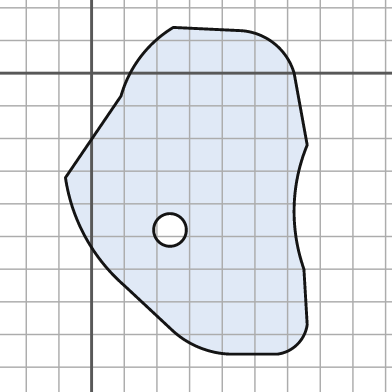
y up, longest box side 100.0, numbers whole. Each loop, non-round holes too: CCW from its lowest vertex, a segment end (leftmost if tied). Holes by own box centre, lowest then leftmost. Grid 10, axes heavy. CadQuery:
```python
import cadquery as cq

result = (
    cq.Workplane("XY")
    .moveTo(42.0, -86.0)
    .lineTo(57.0, -86.0)
    .threePointArc((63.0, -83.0), (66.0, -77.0))
    .lineTo(65.0, -60.0)
    .threePointArc((62.0, -41.0), (66.0, -22.0))
    .lineTo(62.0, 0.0)
    .threePointArc((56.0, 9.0), (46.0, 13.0))
    .lineTo(25.0, 14.0)
    .threePointArc((15.0, 5.0), (9.0, -7.0))
    .lineTo(-8.0, -32.0)
    .threePointArc((-2.0, -50.0), (10.0, -65.0))
    .lineTo(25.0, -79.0)
    .threePointArc((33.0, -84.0), (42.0, -86.0))
    .close()
    .moveTo(24.0, -48.0)
    .circle(5.0)
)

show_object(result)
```